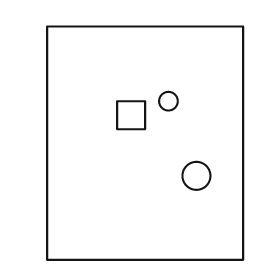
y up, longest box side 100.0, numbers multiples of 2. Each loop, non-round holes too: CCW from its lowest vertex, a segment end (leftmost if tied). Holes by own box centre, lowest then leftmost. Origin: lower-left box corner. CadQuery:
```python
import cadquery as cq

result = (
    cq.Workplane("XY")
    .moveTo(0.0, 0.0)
    .lineTo(84.0, 0.0)
    .lineTo(84.0, 100.0)
    .lineTo(0.0, 100.0)
    .close()
    .moveTo(64.0, 36.0)
    .circle(6.0)
    .moveTo(30.0, 56.0)
    .lineTo(42.0, 56.0)
    .lineTo(42.0, 68.0)
    .lineTo(30.0, 68.0)
    .close()
    .moveTo(52.0, 68.0)
    .circle(4.0)
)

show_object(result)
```